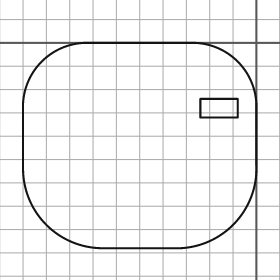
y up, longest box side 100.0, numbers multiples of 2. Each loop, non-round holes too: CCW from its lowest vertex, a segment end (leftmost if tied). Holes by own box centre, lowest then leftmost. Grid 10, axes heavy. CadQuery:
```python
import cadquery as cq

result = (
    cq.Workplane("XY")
    .moveTo(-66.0, -88.0)
    .lineTo(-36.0, -88.0)
    .threePointArc((-10.0, -78.0), (0.0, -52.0))
    .lineTo(0.0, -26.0)
    .threePointArc((-8.0, -8.0), (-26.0, 0.0))
    .lineTo(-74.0, 0.0)
    .threePointArc((-92.0, -8.0), (-100.0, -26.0))
    .lineTo(-100.0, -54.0)
    .threePointArc((-90.0, -78.0), (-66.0, -88.0))
    .close()
    .moveTo(-24.0, -32.0)
    .lineTo(-8.0, -32.0)
    .lineTo(-8.0, -24.0)
    .lineTo(-24.0, -24.0)
    .close()
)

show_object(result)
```